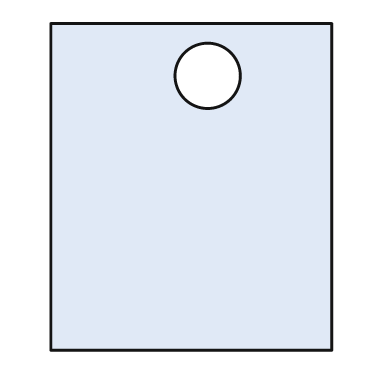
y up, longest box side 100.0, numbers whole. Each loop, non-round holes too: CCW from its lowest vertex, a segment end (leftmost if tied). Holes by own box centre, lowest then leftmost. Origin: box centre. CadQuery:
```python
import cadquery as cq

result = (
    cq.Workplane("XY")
    .moveTo(-43.0, -50.0)
    .lineTo(43.0, -50.0)
    .lineTo(43.0, 50.0)
    .lineTo(-43.0, 50.0)
    .close()
    .moveTo(5.0, 34.0)
    .circle(10.0)
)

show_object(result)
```